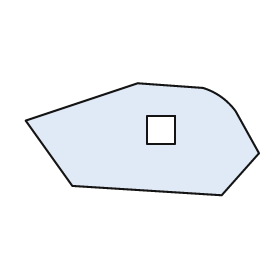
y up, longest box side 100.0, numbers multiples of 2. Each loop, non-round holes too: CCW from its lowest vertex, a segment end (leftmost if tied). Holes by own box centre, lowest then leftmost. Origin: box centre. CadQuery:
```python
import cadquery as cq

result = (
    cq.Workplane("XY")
    .moveTo(34.0, -24.0)
    .lineTo(50.0, -6.0)
    .lineTo(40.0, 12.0)
    .threePointArc((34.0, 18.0), (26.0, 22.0))
    .lineTo(-2.0, 24.0)
    .lineTo(-50.0, 8.0)
    .lineTo(-30.0, -20.0)
    .close()
    .moveTo(2.0, -2.0)
    .lineTo(14.0, -2.0)
    .lineTo(14.0, 10.0)
    .lineTo(2.0, 10.0)
    .close()
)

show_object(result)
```